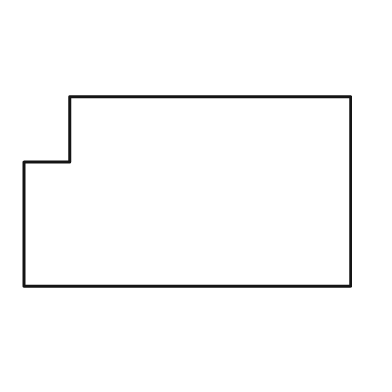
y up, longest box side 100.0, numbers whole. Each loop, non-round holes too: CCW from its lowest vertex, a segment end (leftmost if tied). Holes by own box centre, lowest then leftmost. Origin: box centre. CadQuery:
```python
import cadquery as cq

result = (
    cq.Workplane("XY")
    .moveTo(-50.0, -29.0)
    .lineTo(50.0, -29.0)
    .lineTo(50.0, 29.0)
    .lineTo(-36.0, 29.0)
    .lineTo(-36.0, 9.0)
    .lineTo(-50.0, 9.0)
    .close()
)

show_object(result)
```